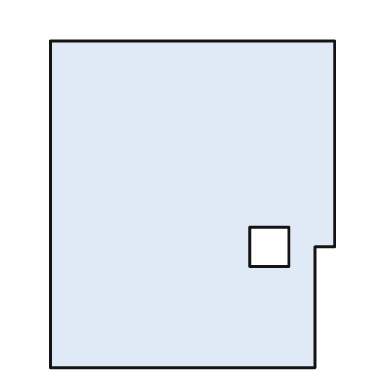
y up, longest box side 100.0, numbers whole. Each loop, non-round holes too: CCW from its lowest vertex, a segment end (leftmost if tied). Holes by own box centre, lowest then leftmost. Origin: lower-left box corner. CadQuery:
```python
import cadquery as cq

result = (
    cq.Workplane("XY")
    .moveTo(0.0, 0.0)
    .lineTo(81.0, 0.0)
    .lineTo(81.0, 37.0)
    .lineTo(87.0, 37.0)
    .lineTo(87.0, 100.0)
    .lineTo(0.0, 100.0)
    .close()
    .moveTo(61.0, 31.0)
    .lineTo(73.0, 31.0)
    .lineTo(73.0, 43.0)
    .lineTo(61.0, 43.0)
    .close()
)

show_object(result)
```